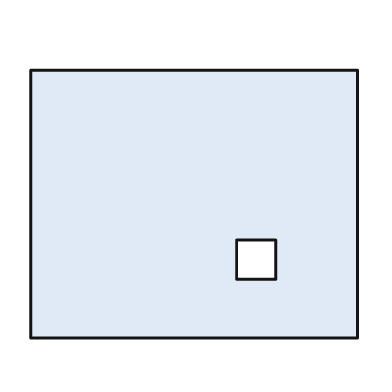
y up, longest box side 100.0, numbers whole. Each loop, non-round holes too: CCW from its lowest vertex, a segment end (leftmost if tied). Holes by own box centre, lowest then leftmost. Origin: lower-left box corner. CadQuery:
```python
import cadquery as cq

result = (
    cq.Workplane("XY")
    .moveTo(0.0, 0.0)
    .lineTo(100.0, 0.0)
    .lineTo(100.0, 82.0)
    .lineTo(0.0, 82.0)
    .close()
    .moveTo(63.0, 18.0)
    .lineTo(75.0, 18.0)
    .lineTo(75.0, 30.0)
    .lineTo(63.0, 30.0)
    .close()
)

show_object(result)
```